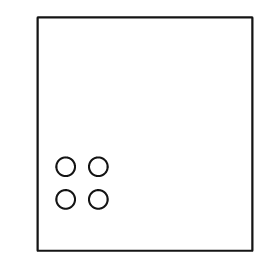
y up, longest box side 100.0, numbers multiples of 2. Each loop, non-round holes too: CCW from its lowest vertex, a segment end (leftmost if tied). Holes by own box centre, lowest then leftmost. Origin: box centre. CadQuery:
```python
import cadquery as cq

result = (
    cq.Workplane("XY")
    .moveTo(-46.0, -50.0)
    .lineTo(46.0, -50.0)
    .lineTo(46.0, 50.0)
    .lineTo(-46.0, 50.0)
    .close()
    .moveTo(-34.0, -28.0)
    .circle(4.0)
    .moveTo(-20.0, -28.0)
    .circle(4.0)
    .moveTo(-34.0, -14.0)
    .circle(4.0)
    .moveTo(-20.0, -14.0)
    .circle(4.0)
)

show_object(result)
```